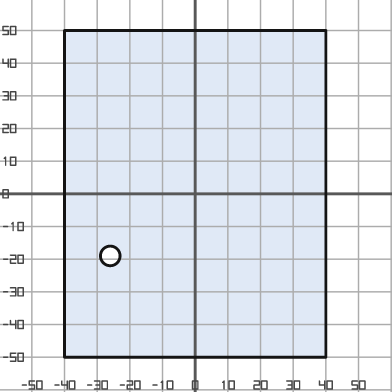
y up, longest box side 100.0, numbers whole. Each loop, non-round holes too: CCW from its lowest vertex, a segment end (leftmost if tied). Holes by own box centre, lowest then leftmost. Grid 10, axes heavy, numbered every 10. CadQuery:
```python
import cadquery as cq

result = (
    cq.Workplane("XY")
    .moveTo(-40.0, -50.0)
    .lineTo(40.0, -50.0)
    .lineTo(40.0, 50.0)
    .lineTo(-40.0, 50.0)
    .close()
    .moveTo(-26.0, -19.0)
    .circle(3.0)
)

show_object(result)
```